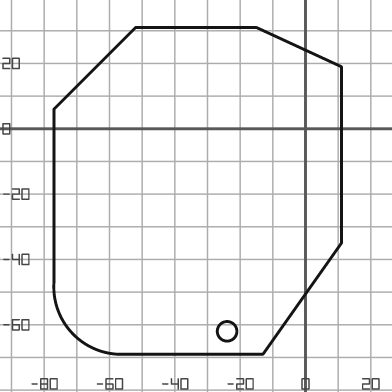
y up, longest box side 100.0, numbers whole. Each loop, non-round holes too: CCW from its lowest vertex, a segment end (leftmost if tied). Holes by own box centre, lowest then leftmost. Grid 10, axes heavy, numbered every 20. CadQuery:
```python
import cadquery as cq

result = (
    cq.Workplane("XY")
    .moveTo(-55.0, -69.0)
    .lineTo(-13.0, -69.0)
    .lineTo(11.0, -35.0)
    .lineTo(11.0, 19.0)
    .lineTo(-15.0, 31.0)
    .lineTo(-52.0, 31.0)
    .lineTo(-77.0, 6.0)
    .lineTo(-77.0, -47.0)
    .threePointArc((-71.0, -63.0), (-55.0, -69.0))
    .close()
    .moveTo(-24.0, -62.0)
    .circle(3.0)
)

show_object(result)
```